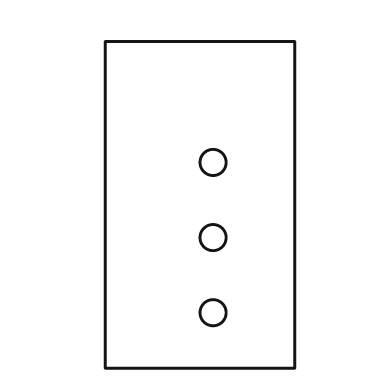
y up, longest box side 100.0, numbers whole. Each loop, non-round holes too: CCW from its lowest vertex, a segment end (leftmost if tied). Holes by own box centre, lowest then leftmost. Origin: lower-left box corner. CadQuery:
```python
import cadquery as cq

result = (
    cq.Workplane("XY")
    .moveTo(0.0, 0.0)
    .lineTo(58.0, 0.0)
    .lineTo(58.0, 100.0)
    .lineTo(0.0, 100.0)
    .close()
    .moveTo(33.0, 17.0)
    .circle(4.0)
    .moveTo(33.0, 40.0)
    .circle(4.0)
    .moveTo(33.0, 63.0)
    .circle(4.0)
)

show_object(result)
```